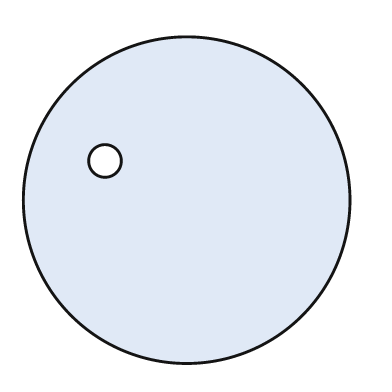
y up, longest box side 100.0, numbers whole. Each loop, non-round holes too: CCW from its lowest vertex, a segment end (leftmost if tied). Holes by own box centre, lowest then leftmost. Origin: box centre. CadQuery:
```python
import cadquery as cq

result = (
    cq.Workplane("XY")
    .moveTo(0.0, 0.0)
    .circle(50.0)
    .moveTo(-25.0, 12.0)
    .circle(5.0)
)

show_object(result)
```